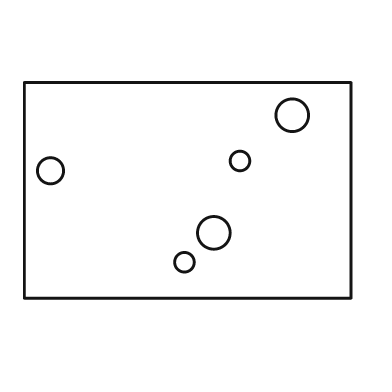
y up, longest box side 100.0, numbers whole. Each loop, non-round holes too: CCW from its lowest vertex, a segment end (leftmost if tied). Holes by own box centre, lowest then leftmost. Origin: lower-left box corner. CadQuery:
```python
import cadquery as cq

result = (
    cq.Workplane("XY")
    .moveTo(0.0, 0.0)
    .lineTo(100.0, 0.0)
    .lineTo(100.0, 66.0)
    .lineTo(0.0, 66.0)
    .close()
    .moveTo(49.0, 11.0)
    .circle(3.0)
    .moveTo(58.0, 20.0)
    .circle(5.0)
    .moveTo(8.0, 39.0)
    .circle(4.0)
    .moveTo(66.0, 42.0)
    .circle(3.0)
    .moveTo(82.0, 56.0)
    .circle(5.0)
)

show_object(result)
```